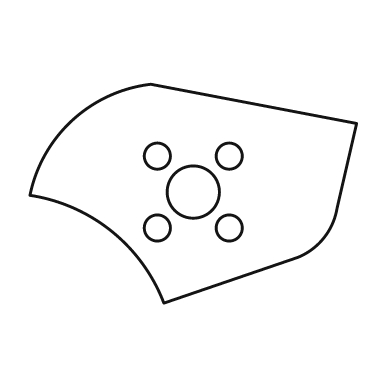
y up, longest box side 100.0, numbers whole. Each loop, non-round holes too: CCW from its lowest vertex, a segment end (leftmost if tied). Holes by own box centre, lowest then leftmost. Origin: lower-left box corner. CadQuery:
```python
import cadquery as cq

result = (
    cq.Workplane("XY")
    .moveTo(41.0, 0.0)
    .lineTo(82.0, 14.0)
    .threePointArc((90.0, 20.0), (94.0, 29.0))
    .lineTo(100.0, 55.0)
    .lineTo(37.0, 67.0)
    .threePointArc((13.0, 56.0), (0.0, 33.0))
    .threePointArc((25.0, 22.0), (41.0, 0.0))
    .close()
    .moveTo(39.0, 23.0)
    .circle(4.0)
    .moveTo(61.0, 23.0)
    .circle(4.0)
    .moveTo(50.0, 34.0)
    .circle(8.0)
    .moveTo(39.0, 45.0)
    .circle(4.0)
    .moveTo(61.0, 45.0)
    .circle(4.0)
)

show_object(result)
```